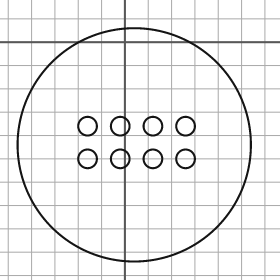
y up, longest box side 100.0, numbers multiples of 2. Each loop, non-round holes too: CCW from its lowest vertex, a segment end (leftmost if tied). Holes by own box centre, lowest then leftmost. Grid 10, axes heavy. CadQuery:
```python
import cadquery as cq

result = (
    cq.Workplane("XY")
    .moveTo(4.0, -44.0)
    .circle(50.0)
    .moveTo(-16.0, -50.0)
    .circle(4.0)
    .moveTo(-2.0, -50.0)
    .circle(4.0)
    .moveTo(12.0, -50.0)
    .circle(4.0)
    .moveTo(26.0, -50.0)
    .circle(4.0)
    .moveTo(-16.0, -36.0)
    .circle(4.0)
    .moveTo(-2.0, -36.0)
    .circle(4.0)
    .moveTo(12.0, -36.0)
    .circle(4.0)
    .moveTo(26.0, -36.0)
    .circle(4.0)
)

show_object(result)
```